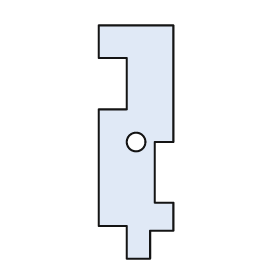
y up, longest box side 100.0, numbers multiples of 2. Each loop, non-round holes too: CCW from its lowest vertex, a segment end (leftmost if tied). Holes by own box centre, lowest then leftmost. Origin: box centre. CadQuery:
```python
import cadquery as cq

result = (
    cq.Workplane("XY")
    .moveTo(-4.0, -50.0)
    .lineTo(6.0, -50.0)
    .lineTo(6.0, -38.0)
    .lineTo(16.0, -38.0)
    .lineTo(16.0, -26.0)
    .lineTo(8.0, -26.0)
    .lineTo(8.0, 0.0)
    .lineTo(16.0, 0.0)
    .lineTo(16.0, 50.0)
    .lineTo(-16.0, 50.0)
    .lineTo(-16.0, 36.0)
    .lineTo(-4.0, 36.0)
    .lineTo(-4.0, 14.0)
    .lineTo(-16.0, 14.0)
    .lineTo(-16.0, -36.0)
    .lineTo(-4.0, -36.0)
    .close()
    .moveTo(0.0, 0.0)
    .circle(4.0)
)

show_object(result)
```